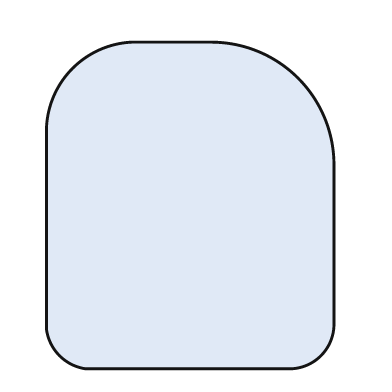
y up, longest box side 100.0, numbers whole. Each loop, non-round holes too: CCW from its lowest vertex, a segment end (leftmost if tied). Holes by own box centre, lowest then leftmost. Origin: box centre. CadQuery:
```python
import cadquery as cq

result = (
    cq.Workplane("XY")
    .moveTo(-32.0, -50.0)
    .lineTo(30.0, -50.0)
    .threePointArc((40.0, -46.0), (44.0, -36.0))
    .lineTo(44.0, 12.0)
    .threePointArc((33.0, 39.0), (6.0, 50.0))
    .lineTo(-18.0, 50.0)
    .threePointArc((-36.0, 42.0), (-44.0, 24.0))
    .lineTo(-44.0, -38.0)
    .threePointArc((-40.0, -46.0), (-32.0, -50.0))
    .close()
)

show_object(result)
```